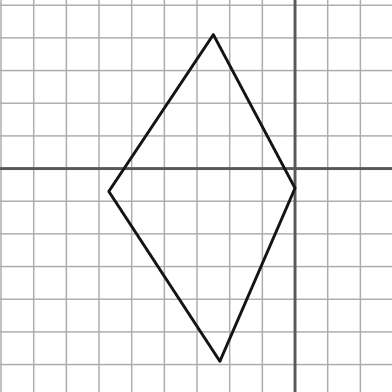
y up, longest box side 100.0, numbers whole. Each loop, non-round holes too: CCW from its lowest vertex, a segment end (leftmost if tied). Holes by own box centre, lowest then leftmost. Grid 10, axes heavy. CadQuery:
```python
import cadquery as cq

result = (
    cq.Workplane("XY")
    .moveTo(-23.0, -59.0)
    .lineTo(0.0, -6.0)
    .lineTo(-25.0, 41.0)
    .lineTo(-57.0, -7.0)
    .close()
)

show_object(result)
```